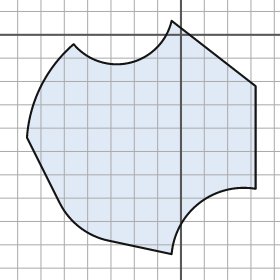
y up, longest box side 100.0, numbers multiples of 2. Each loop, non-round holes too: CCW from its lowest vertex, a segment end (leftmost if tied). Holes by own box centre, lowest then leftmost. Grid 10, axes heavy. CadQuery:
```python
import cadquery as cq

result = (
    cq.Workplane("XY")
    .moveTo(-4.0, -94.0)
    .threePointArc((8.0, -72.0), (32.0, -66.0))
    .lineTo(32.0, -22.0)
    .lineTo(-4.0, 6.0)
    .threePointArc((-22.0, -12.0), (-46.0, -4.0))
    .threePointArc((-60.0, -22.0), (-66.0, -44.0))
    .lineTo(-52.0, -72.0)
    .threePointArc((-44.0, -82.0), (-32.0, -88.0))
    .close()
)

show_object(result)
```